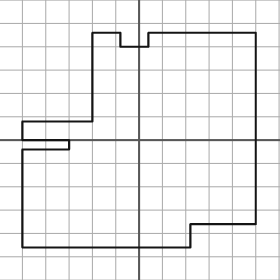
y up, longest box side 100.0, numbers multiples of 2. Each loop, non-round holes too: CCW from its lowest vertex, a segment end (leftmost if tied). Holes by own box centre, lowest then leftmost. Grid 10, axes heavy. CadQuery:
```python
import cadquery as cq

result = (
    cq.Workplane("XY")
    .moveTo(-50.0, -46.0)
    .lineTo(22.0, -46.0)
    .lineTo(22.0, -36.0)
    .lineTo(50.0, -36.0)
    .lineTo(50.0, 46.0)
    .lineTo(4.0, 46.0)
    .lineTo(4.0, 40.0)
    .lineTo(-8.0, 40.0)
    .lineTo(-8.0, 46.0)
    .lineTo(-20.0, 46.0)
    .lineTo(-20.0, 8.0)
    .lineTo(-50.0, 8.0)
    .lineTo(-50.0, 0.0)
    .lineTo(-30.0, 0.0)
    .lineTo(-30.0, -4.0)
    .lineTo(-50.0, -4.0)
    .close()
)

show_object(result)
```